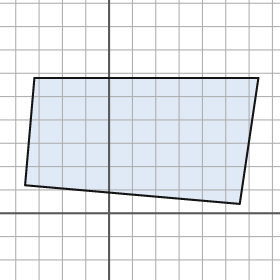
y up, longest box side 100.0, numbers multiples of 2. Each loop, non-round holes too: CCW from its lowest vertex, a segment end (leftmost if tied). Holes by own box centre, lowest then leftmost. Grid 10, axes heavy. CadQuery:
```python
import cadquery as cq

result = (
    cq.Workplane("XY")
    .moveTo(56.0, 4.0)
    .lineTo(64.0, 58.0)
    .lineTo(-32.0, 58.0)
    .lineTo(-36.0, 12.0)
    .close()
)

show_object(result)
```